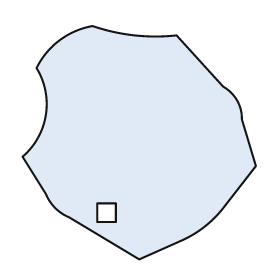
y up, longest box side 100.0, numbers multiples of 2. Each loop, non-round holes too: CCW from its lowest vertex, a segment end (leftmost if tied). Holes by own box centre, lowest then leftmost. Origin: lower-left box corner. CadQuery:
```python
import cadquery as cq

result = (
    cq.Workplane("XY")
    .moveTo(50.0, 0.0)
    .lineTo(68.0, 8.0)
    .threePointArc((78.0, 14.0), (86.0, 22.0))
    .lineTo(100.0, 40.0)
    .lineTo(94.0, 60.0)
    .threePointArc((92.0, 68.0), (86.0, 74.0))
    .lineTo(66.0, 96.0)
    .threePointArc((48.0, 96.0), (30.0, 100.0))
    .threePointArc((16.0, 94.0), (6.0, 82.0))
    .threePointArc((10.0, 62.0), (0.0, 44.0))
    .lineTo(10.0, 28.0)
    .threePointArc((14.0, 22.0), (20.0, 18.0))
    .close()
    .moveTo(32.0, 16.0)
    .lineTo(40.0, 16.0)
    .lineTo(40.0, 24.0)
    .lineTo(32.0, 24.0)
    .close()
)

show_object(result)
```